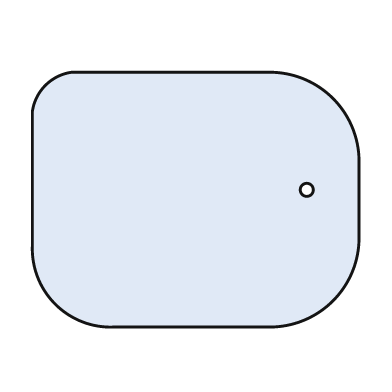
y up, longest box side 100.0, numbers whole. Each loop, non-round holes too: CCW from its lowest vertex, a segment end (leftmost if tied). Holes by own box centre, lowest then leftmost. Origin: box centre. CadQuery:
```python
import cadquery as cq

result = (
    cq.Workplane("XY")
    .moveTo(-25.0, -39.0)
    .lineTo(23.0, -39.0)
    .threePointArc((42.0, -31.0), (50.0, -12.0))
    .lineTo(50.0, 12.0)
    .threePointArc((42.0, 31.0), (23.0, 39.0))
    .lineTo(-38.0, 39.0)
    .threePointArc((-46.0, 35.0), (-50.0, 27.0))
    .lineTo(-50.0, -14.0)
    .threePointArc((-43.0, -32.0), (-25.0, -39.0))
    .close()
    .moveTo(34.0, 3.0)
    .circle(2.0)
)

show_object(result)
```